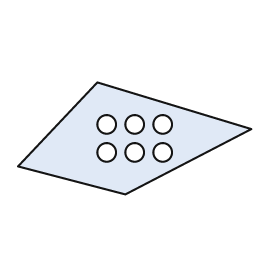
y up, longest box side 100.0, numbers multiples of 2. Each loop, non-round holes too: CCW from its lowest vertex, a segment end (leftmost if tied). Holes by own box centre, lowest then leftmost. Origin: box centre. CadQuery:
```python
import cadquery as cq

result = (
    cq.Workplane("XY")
    .moveTo(-4.0, -24.0)
    .lineTo(50.0, 4.0)
    .lineTo(-16.0, 24.0)
    .lineTo(-50.0, -12.0)
    .close()
    .moveTo(-12.0, -6.0)
    .circle(4.0)
    .moveTo(0.0, -6.0)
    .circle(4.0)
    .moveTo(12.0, -6.0)
    .circle(4.0)
    .moveTo(-12.0, 6.0)
    .circle(4.0)
    .moveTo(0.0, 6.0)
    .circle(4.0)
    .moveTo(12.0, 6.0)
    .circle(4.0)
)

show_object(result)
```